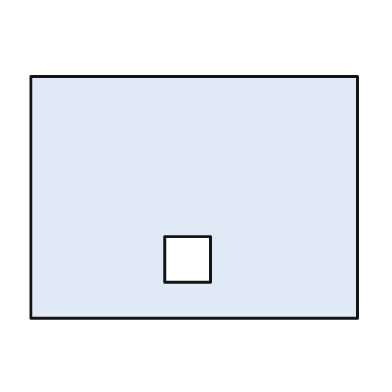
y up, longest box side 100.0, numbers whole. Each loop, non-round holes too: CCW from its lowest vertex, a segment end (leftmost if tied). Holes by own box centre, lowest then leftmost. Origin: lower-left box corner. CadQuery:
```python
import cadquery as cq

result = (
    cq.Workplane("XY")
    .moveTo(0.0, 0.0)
    .lineTo(100.0, 0.0)
    .lineTo(100.0, 74.0)
    .lineTo(0.0, 74.0)
    .close()
    .moveTo(41.0, 11.0)
    .lineTo(55.0, 11.0)
    .lineTo(55.0, 25.0)
    .lineTo(41.0, 25.0)
    .close()
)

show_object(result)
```